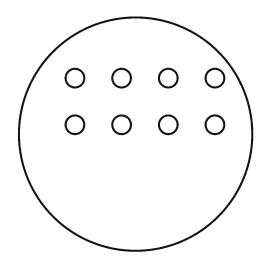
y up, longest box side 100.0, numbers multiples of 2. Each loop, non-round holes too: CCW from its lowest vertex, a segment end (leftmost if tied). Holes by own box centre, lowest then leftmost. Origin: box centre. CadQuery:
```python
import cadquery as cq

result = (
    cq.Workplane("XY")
    .moveTo(0.0, 0.0)
    .circle(50.0)
    .moveTo(-26.0, 4.0)
    .circle(4.0)
    .moveTo(-6.0, 4.0)
    .circle(4.0)
    .moveTo(14.0, 4.0)
    .circle(4.0)
    .moveTo(34.0, 4.0)
    .circle(4.0)
    .moveTo(-26.0, 24.0)
    .circle(4.0)
    .moveTo(-6.0, 24.0)
    .circle(4.0)
    .moveTo(14.0, 24.0)
    .circle(4.0)
    .moveTo(34.0, 24.0)
    .circle(4.0)
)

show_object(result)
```